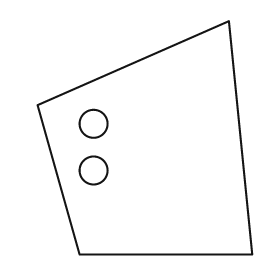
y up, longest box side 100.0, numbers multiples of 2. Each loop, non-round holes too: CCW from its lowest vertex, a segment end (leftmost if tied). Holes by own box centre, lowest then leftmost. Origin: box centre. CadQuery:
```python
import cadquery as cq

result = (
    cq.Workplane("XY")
    .moveTo(-28.0, -50.0)
    .lineTo(46.0, -50.0)
    .lineTo(36.0, 50.0)
    .lineTo(-46.0, 14.0)
    .close()
    .moveTo(-22.0, -14.0)
    .circle(6.0)
    .moveTo(-22.0, 6.0)
    .circle(6.0)
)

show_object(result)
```